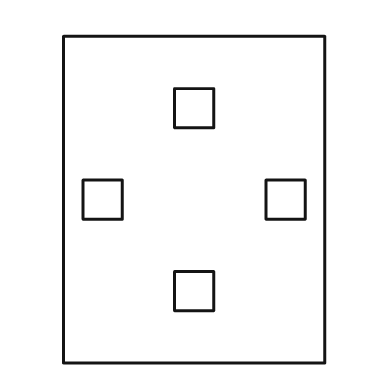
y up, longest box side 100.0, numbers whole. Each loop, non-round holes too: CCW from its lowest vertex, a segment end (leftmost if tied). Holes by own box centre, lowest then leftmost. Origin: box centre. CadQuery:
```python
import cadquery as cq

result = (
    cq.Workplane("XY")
    .moveTo(-40.0, -50.0)
    .lineTo(40.0, -50.0)
    .lineTo(40.0, 50.0)
    .lineTo(-40.0, 50.0)
    .close()
    .moveTo(-6.0, -34.0)
    .lineTo(6.0, -34.0)
    .lineTo(6.0, -22.0)
    .lineTo(-6.0, -22.0)
    .close()
    .moveTo(-34.0, -6.0)
    .lineTo(-22.0, -6.0)
    .lineTo(-22.0, 6.0)
    .lineTo(-34.0, 6.0)
    .close()
    .moveTo(22.0, -6.0)
    .lineTo(34.0, -6.0)
    .lineTo(34.0, 6.0)
    .lineTo(22.0, 6.0)
    .close()
    .moveTo(-6.0, 22.0)
    .lineTo(6.0, 22.0)
    .lineTo(6.0, 34.0)
    .lineTo(-6.0, 34.0)
    .close()
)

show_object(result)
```